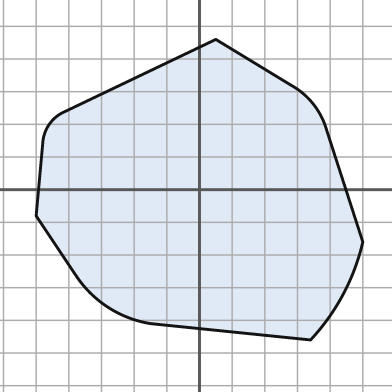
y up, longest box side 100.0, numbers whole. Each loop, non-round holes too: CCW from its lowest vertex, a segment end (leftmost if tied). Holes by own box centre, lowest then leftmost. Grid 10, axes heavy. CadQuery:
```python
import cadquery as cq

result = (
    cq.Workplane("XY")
    .moveTo(34.0, -46.0)
    .threePointArc((44.0, -32.0), (50.0, -16.0))
    .lineTo(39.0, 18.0)
    .threePointArc((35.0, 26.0), (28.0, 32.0))
    .lineTo(5.0, 46.0)
    .lineTo(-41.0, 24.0)
    .threePointArc((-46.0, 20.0), (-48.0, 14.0))
    .lineTo(-50.0, -8.0)
    .lineTo(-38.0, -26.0)
    .threePointArc((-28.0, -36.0), (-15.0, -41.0))
    .close()
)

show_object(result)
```